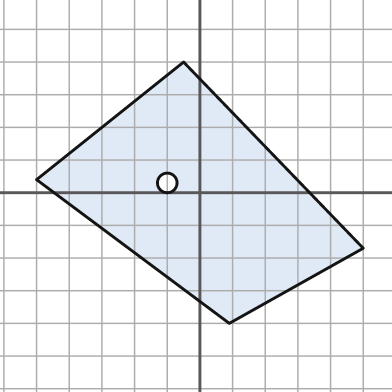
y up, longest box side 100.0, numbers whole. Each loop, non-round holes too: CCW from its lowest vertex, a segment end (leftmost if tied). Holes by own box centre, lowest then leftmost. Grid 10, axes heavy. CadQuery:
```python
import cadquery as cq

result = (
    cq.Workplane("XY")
    .moveTo(9.0, -40.0)
    .lineTo(50.0, -17.0)
    .lineTo(-5.0, 40.0)
    .lineTo(-50.0, 4.0)
    .close()
    .moveTo(-10.0, 3.0)
    .circle(3.0)
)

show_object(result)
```